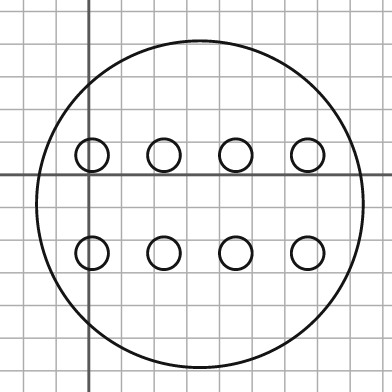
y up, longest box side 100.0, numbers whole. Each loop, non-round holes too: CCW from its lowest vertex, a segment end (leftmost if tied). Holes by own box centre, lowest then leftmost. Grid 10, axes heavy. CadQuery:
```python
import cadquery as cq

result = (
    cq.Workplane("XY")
    .moveTo(34.0, -9.0)
    .circle(50.0)
    .moveTo(1.0, -24.0)
    .circle(5.0)
    .moveTo(23.0, -24.0)
    .circle(5.0)
    .moveTo(45.0, -24.0)
    .circle(5.0)
    .moveTo(67.0, -24.0)
    .circle(5.0)
    .moveTo(1.0, 6.0)
    .circle(5.0)
    .moveTo(23.0, 6.0)
    .circle(5.0)
    .moveTo(45.0, 6.0)
    .circle(5.0)
    .moveTo(67.0, 6.0)
    .circle(5.0)
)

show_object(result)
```